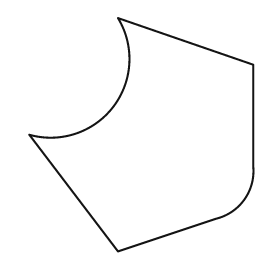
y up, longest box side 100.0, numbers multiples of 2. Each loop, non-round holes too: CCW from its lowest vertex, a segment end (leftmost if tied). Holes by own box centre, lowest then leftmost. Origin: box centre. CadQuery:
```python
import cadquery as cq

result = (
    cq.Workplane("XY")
    .moveTo(-10.0, -50.0)
    .lineTo(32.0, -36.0)
    .threePointArc((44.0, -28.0), (48.0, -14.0))
    .lineTo(48.0, 30.0)
    .lineTo(-10.0, 50.0)
    .threePointArc((-12.0, 12.0), (-48.0, 0.0))
    .close()
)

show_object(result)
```